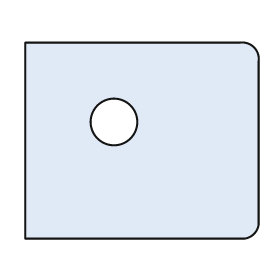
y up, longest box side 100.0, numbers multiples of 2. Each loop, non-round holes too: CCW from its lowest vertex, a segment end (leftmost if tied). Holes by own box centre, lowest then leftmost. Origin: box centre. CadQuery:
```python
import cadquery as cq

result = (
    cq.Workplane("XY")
    .moveTo(-50.0, -42.0)
    .lineTo(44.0, -42.0)
    .threePointArc((48.0, -40.0), (50.0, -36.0))
    .lineTo(50.0, 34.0)
    .threePointArc((48.0, 40.0), (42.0, 42.0))
    .lineTo(-50.0, 42.0)
    .close()
    .moveTo(-12.0, 8.0)
    .circle(10.0)
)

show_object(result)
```